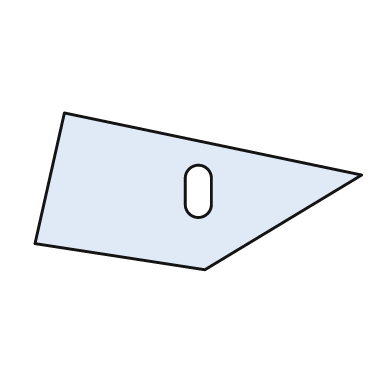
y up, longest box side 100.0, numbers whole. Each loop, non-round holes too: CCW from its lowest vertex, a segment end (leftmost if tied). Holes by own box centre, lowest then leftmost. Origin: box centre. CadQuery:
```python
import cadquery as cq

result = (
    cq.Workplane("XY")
    .moveTo(2.0, -24.0)
    .lineTo(50.0, 5.0)
    .lineTo(-41.0, 24.0)
    .lineTo(-50.0, -16.0)
    .close()
    .moveTo(-4.0, -4.0)
    .threePointArc((0.0, -8.0), (4.0, -4.0))
    .lineTo(4.0, 4.0)
    .threePointArc((0.0, 8.0), (-4.0, 4.0))
    .close()
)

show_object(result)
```